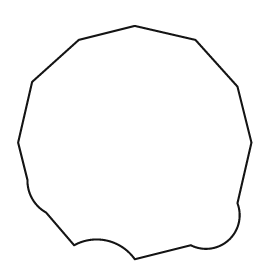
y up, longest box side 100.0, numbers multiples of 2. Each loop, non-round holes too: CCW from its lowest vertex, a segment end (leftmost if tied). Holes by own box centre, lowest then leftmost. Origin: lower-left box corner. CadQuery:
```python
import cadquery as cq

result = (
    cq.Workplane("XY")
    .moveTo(50.0, 0.0)
    .lineTo(74.0, 6.0)
    .threePointArc((90.0, 8.0), (94.0, 24.0))
    .lineTo(100.0, 50.0)
    .lineTo(94.0, 74.0)
    .lineTo(76.0, 94.0)
    .lineTo(50.0, 100.0)
    .lineTo(26.0, 94.0)
    .lineTo(6.0, 76.0)
    .lineTo(0.0, 50.0)
    .lineTo(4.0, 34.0)
    .threePointArc((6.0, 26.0), (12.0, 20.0))
    .lineTo(24.0, 6.0)
    .threePointArc((38.0, 8.0), (50.0, 0.0))
    .close()
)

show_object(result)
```